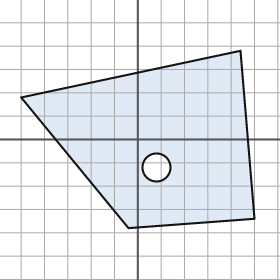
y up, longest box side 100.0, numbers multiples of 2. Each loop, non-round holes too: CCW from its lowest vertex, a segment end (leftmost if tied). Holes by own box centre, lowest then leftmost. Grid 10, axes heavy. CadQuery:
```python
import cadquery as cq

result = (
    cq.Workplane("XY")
    .moveTo(-4.0, -38.0)
    .lineTo(50.0, -34.0)
    .lineTo(44.0, 38.0)
    .lineTo(-50.0, 18.0)
    .close()
    .moveTo(8.0, -12.0)
    .circle(6.0)
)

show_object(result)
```